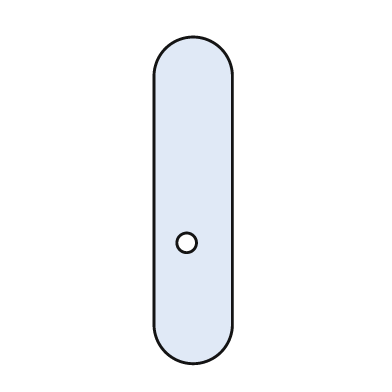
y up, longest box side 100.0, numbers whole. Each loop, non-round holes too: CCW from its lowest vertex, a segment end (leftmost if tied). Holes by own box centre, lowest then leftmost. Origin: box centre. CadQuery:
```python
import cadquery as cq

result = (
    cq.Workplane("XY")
    .moveTo(-12.0, -38.0)
    .threePointArc((0.0, -50.0), (12.0, -38.0))
    .lineTo(12.0, 38.0)
    .threePointArc((0.0, 50.0), (-12.0, 38.0))
    .close()
    .moveTo(-2.0, -13.0)
    .circle(3.0)
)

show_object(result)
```